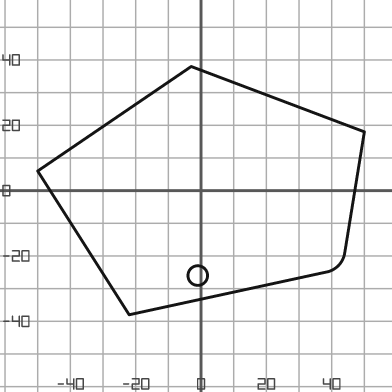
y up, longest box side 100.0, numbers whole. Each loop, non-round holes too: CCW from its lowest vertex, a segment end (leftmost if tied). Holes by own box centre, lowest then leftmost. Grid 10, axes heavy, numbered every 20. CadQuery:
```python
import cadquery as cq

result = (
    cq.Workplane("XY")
    .moveTo(-22.0, -38.0)
    .lineTo(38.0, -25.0)
    .threePointArc((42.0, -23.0), (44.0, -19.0))
    .lineTo(50.0, 18.0)
    .lineTo(-3.0, 38.0)
    .lineTo(-50.0, 6.0)
    .close()
    .moveTo(-1.0, -26.0)
    .circle(3.0)
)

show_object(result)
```